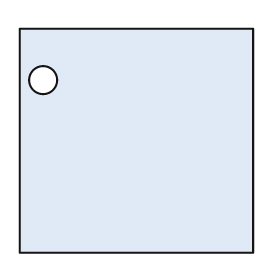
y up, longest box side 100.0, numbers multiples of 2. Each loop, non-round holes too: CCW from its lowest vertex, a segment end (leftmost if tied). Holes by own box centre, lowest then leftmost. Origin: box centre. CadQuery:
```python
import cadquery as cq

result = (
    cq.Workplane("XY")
    .moveTo(-50.0, -48.0)
    .lineTo(50.0, -48.0)
    .lineTo(50.0, 48.0)
    .lineTo(-50.0, 48.0)
    .close()
    .moveTo(-40.0, 26.0)
    .circle(6.0)
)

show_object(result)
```